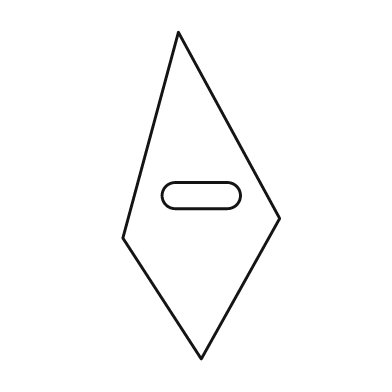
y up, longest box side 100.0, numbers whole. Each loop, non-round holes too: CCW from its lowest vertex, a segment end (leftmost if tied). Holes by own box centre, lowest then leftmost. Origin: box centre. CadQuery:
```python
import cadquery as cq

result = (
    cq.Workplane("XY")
    .moveTo(0.0, -50.0)
    .lineTo(24.0, -7.0)
    .lineTo(-7.0, 50.0)
    .lineTo(-24.0, -13.0)
    .close()
    .moveTo(-8.0, -4.0)
    .lineTo(8.0, -4.0)
    .threePointArc((12.0, 0.0), (8.0, 4.0))
    .lineTo(-8.0, 4.0)
    .threePointArc((-12.0, 0.0), (-8.0, -4.0))
    .close()
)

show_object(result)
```